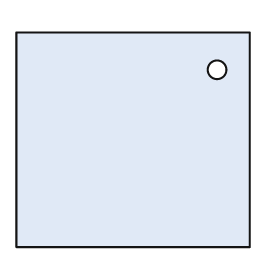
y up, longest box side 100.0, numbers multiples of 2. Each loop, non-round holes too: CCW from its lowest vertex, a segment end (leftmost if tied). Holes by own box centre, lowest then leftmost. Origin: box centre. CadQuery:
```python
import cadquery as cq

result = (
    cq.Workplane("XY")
    .moveTo(-50.0, -46.0)
    .lineTo(50.0, -46.0)
    .lineTo(50.0, 46.0)
    .lineTo(-50.0, 46.0)
    .close()
    .moveTo(36.0, 30.0)
    .circle(4.0)
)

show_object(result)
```